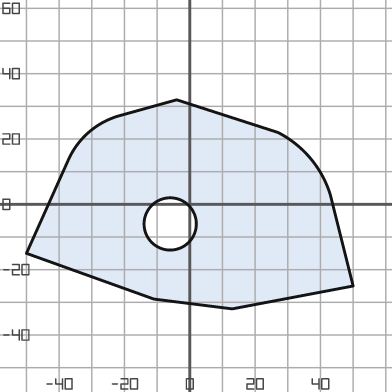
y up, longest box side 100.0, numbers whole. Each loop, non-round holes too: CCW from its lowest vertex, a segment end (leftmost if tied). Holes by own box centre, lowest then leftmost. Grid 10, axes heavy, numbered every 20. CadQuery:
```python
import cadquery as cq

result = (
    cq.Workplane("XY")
    .moveTo(13.0, -32.0)
    .lineTo(50.0, -25.0)
    .lineTo(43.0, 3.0)
    .threePointArc((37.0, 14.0), (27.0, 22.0))
    .lineTo(-4.0, 32.0)
    .lineTo(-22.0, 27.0)
    .threePointArc((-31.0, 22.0), (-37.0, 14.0))
    .lineTo(-50.0, -15.0)
    .lineTo(-11.0, -29.0)
    .close()
    .moveTo(-6.0, -6.0)
    .circle(8.0)
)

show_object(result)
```